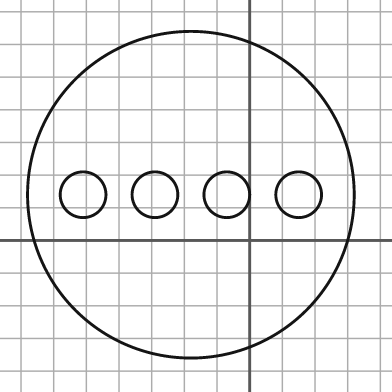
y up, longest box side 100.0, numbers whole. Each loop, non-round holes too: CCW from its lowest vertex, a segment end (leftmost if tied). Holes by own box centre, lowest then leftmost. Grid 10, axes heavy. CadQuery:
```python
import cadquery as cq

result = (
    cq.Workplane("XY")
    .moveTo(-18.0, 14.0)
    .circle(50.0)
    .moveTo(-51.0, 14.0)
    .circle(7.0)
    .moveTo(-29.0, 14.0)
    .circle(7.0)
    .moveTo(-7.0, 14.0)
    .circle(7.0)
    .moveTo(15.0, 14.0)
    .circle(7.0)
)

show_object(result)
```